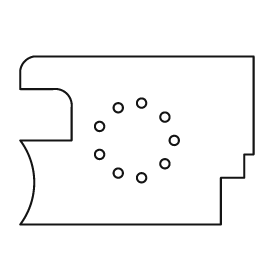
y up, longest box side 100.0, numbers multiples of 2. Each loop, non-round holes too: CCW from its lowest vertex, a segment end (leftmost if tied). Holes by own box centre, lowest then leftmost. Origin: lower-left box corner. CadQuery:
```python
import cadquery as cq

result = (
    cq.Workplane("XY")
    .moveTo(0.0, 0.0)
    .lineTo(86.0, 0.0)
    .lineTo(86.0, 20.0)
    .lineTo(96.0, 20.0)
    .lineTo(96.0, 30.0)
    .lineTo(100.0, 30.0)
    .lineTo(100.0, 72.0)
    .lineTo(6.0, 72.0)
    .threePointArc((2.0, 70.0), (0.0, 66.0))
    .lineTo(0.0, 58.0)
    .lineTo(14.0, 58.0)
    .threePointArc((20.0, 56.0), (22.0, 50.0))
    .lineTo(22.0, 36.0)
    .lineTo(0.0, 36.0)
    .threePointArc((6.0, 18.0), (0.0, 0.0))
    .close()
    .moveTo(52.0, 20.0)
    .circle(2.0)
    .moveTo(42.0, 22.0)
    .circle(2.0)
    .moveTo(62.0, 26.0)
    .circle(2.0)
    .moveTo(34.0, 30.0)
    .circle(2.0)
    .moveTo(66.0, 36.0)
    .circle(2.0)
    .moveTo(34.0, 42.0)
    .circle(2.0)
    .moveTo(62.0, 46.0)
    .circle(2.0)
    .moveTo(42.0, 50.0)
    .circle(2.0)
    .moveTo(52.0, 52.0)
    .circle(2.0)
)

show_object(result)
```